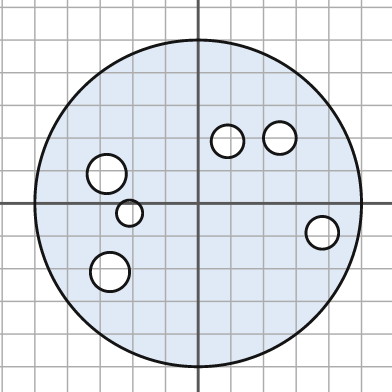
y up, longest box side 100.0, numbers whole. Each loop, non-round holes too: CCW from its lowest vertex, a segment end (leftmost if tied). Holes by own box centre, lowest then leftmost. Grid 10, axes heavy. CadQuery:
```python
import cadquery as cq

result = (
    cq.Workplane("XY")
    .moveTo(0.0, 0.0)
    .circle(50.0)
    .moveTo(-27.0, -21.0)
    .circle(6.0)
    .moveTo(38.0, -9.0)
    .circle(5.0)
    .moveTo(-21.0, -3.0)
    .circle(4.0)
    .moveTo(-28.0, 9.0)
    .circle(6.0)
    .moveTo(9.0, 19.0)
    .circle(5.0)
    .moveTo(25.0, 20.0)
    .circle(5.0)
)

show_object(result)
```